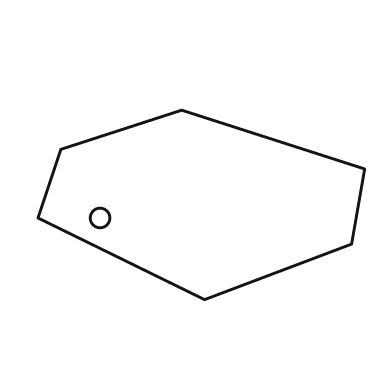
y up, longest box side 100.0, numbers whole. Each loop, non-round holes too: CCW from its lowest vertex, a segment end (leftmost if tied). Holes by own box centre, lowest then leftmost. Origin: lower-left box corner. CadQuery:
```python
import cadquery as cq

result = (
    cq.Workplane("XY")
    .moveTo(51.0, 0.0)
    .lineTo(96.0, 17.0)
    .lineTo(100.0, 40.0)
    .lineTo(44.0, 58.0)
    .lineTo(7.0, 46.0)
    .lineTo(0.0, 25.0)
    .close()
    .moveTo(19.0, 25.0)
    .circle(3.0)
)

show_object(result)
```